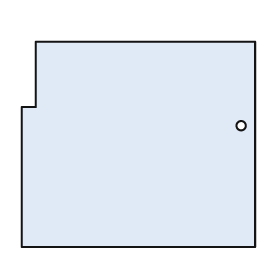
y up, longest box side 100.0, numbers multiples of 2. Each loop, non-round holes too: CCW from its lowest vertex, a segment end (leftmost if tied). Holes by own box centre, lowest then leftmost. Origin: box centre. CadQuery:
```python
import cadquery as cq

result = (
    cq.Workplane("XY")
    .moveTo(-50.0, -44.0)
    .lineTo(50.0, -44.0)
    .lineTo(50.0, 44.0)
    .lineTo(-44.0, 44.0)
    .lineTo(-44.0, 16.0)
    .lineTo(-50.0, 16.0)
    .close()
    .moveTo(44.0, 8.0)
    .circle(2.0)
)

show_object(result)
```